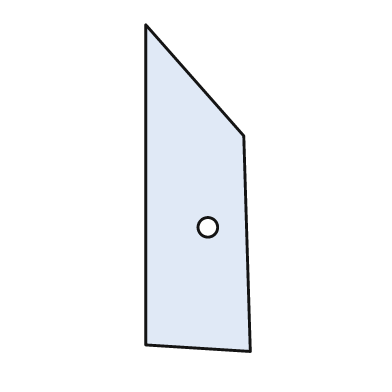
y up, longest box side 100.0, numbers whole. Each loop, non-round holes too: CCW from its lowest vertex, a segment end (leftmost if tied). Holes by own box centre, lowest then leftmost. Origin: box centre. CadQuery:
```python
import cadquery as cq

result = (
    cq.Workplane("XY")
    .moveTo(16.0, -50.0)
    .lineTo(14.0, 16.0)
    .lineTo(-16.0, 50.0)
    .lineTo(-16.0, -48.0)
    .close()
    .moveTo(3.0, -12.0)
    .circle(3.0)
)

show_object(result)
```